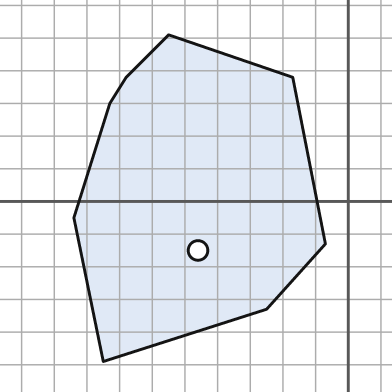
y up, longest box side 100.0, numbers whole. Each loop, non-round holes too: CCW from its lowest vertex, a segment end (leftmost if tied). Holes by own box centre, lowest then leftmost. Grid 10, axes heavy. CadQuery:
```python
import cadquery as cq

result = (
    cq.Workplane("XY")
    .moveTo(-75.0, -49.0)
    .lineTo(-25.0, -33.0)
    .lineTo(-7.0, -13.0)
    .lineTo(-17.0, 38.0)
    .lineTo(-55.0, 51.0)
    .lineTo(-68.0, 38.0)
    .lineTo(-73.0, 30.0)
    .lineTo(-84.0, -5.0)
    .close()
    .moveTo(-46.0, -15.0)
    .circle(3.0)
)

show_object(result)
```